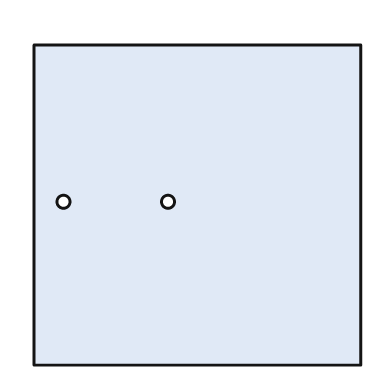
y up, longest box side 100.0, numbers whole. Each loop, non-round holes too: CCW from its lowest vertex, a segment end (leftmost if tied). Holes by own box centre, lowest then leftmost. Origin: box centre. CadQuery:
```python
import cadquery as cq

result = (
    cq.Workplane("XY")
    .moveTo(-50.0, -49.0)
    .lineTo(50.0, -49.0)
    .lineTo(50.0, 49.0)
    .lineTo(-50.0, 49.0)
    .close()
    .moveTo(-41.0, 1.0)
    .circle(2.0)
    .moveTo(-9.0, 1.0)
    .circle(2.0)
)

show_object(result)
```